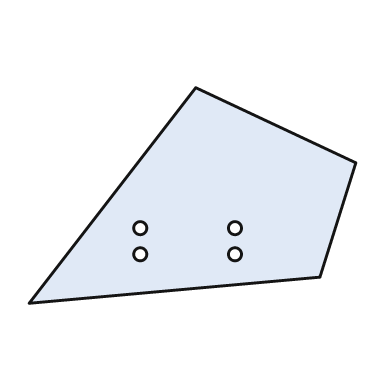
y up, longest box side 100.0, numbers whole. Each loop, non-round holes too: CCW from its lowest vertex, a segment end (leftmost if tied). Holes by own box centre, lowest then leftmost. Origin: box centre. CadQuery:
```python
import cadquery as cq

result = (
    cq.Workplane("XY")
    .moveTo(-50.0, -33.0)
    .lineTo(39.0, -25.0)
    .lineTo(50.0, 10.0)
    .lineTo(1.0, 33.0)
    .close()
    .moveTo(-16.0, -18.0)
    .circle(2.0)
    .moveTo(13.0, -18.0)
    .circle(2.0)
    .moveTo(-16.0, -10.0)
    .circle(2.0)
    .moveTo(13.0, -10.0)
    .circle(2.0)
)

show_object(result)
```